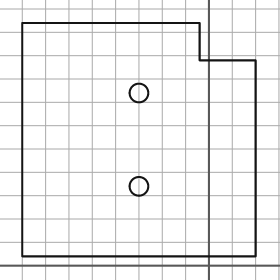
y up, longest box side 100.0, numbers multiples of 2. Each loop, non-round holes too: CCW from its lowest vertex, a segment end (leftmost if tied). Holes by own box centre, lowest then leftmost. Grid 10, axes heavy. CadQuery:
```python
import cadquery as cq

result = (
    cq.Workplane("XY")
    .moveTo(-80.0, 4.0)
    .lineTo(20.0, 4.0)
    .lineTo(20.0, 88.0)
    .lineTo(-4.0, 88.0)
    .lineTo(-4.0, 104.0)
    .lineTo(-80.0, 104.0)
    .close()
    .moveTo(-30.0, 34.0)
    .circle(4.0)
    .moveTo(-30.0, 74.0)
    .circle(4.0)
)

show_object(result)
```